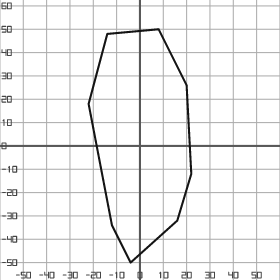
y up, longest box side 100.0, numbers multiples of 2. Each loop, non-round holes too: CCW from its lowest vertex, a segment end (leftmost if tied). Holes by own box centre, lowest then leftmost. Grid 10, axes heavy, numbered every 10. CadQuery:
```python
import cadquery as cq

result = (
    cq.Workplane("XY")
    .moveTo(-4.0, -50.0)
    .lineTo(16.0, -32.0)
    .lineTo(22.0, -12.0)
    .lineTo(20.0, 26.0)
    .lineTo(8.0, 50.0)
    .lineTo(-14.0, 48.0)
    .lineTo(-22.0, 18.0)
    .lineTo(-12.0, -34.0)
    .close()
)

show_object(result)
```